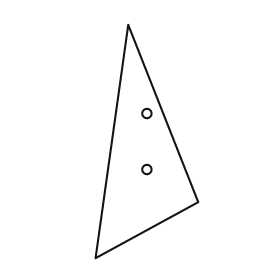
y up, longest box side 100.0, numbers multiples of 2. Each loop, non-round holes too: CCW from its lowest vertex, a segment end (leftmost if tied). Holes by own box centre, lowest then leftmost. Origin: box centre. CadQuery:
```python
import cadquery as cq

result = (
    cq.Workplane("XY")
    .moveTo(-22.0, -50.0)
    .lineTo(22.0, -26.0)
    .lineTo(-8.0, 50.0)
    .close()
    .moveTo(0.0, -12.0)
    .circle(2.0)
    .moveTo(0.0, 12.0)
    .circle(2.0)
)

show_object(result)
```